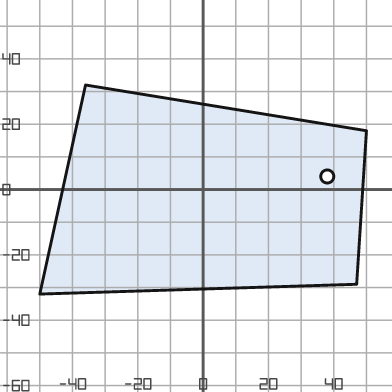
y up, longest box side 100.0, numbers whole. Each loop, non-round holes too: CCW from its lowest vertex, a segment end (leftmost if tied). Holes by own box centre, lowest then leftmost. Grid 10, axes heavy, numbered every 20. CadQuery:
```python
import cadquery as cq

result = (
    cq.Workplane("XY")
    .moveTo(-50.0, -32.0)
    .lineTo(47.0, -29.0)
    .lineTo(50.0, 18.0)
    .lineTo(-36.0, 32.0)
    .close()
    .moveTo(38.0, 4.0)
    .circle(2.0)
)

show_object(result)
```